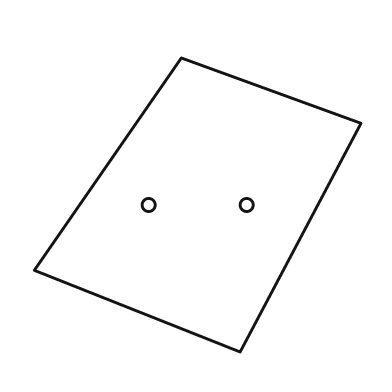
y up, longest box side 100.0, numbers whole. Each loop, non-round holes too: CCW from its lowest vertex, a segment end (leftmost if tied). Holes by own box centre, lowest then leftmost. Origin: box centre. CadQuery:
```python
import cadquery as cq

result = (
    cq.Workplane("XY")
    .moveTo(13.0, -45.0)
    .lineTo(50.0, 25.0)
    .lineTo(-5.0, 45.0)
    .lineTo(-50.0, -20.0)
    .close()
    .moveTo(-15.0, 0.0)
    .circle(2.0)
    .moveTo(15.0, 0.0)
    .circle(2.0)
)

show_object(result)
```